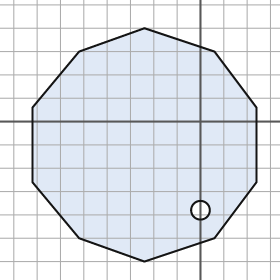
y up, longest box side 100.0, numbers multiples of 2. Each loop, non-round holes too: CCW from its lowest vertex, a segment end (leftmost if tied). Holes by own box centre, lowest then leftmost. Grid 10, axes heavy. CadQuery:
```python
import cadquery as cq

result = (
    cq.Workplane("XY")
    .moveTo(-24.0, -60.0)
    .lineTo(6.0, -50.0)
    .lineTo(24.0, -26.0)
    .lineTo(24.0, 6.0)
    .lineTo(6.0, 30.0)
    .lineTo(-24.0, 40.0)
    .lineTo(-52.0, 30.0)
    .lineTo(-72.0, 6.0)
    .lineTo(-72.0, -26.0)
    .lineTo(-52.0, -50.0)
    .close()
    .moveTo(0.0, -38.0)
    .circle(4.0)
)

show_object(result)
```